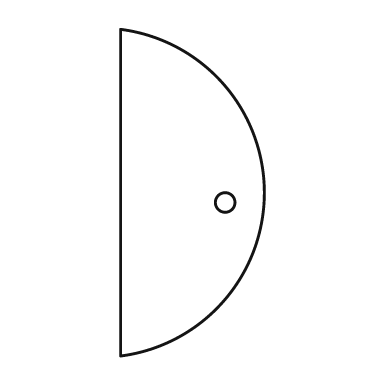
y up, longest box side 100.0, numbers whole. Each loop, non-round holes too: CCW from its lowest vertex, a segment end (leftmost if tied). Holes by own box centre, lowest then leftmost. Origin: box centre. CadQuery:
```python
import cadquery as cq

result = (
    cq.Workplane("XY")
    .moveTo(-22.0, -50.0)
    .threePointArc((22.0, 0.0), (-22.0, 50.0))
    .close()
    .moveTo(10.0, -3.0)
    .circle(3.0)
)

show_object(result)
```